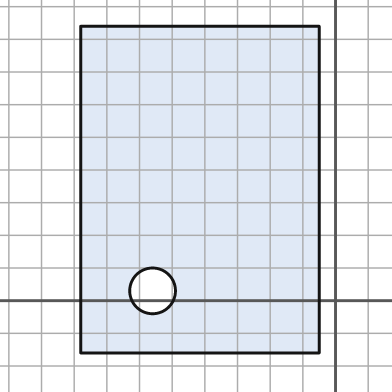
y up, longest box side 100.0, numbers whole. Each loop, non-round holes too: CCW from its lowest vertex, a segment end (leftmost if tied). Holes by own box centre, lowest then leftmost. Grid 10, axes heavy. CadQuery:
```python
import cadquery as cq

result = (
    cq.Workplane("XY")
    .moveTo(-78.0, -16.0)
    .lineTo(-5.0, -16.0)
    .lineTo(-5.0, 84.0)
    .lineTo(-78.0, 84.0)
    .close()
    .moveTo(-56.0, 3.0)
    .circle(7.0)
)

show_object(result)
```